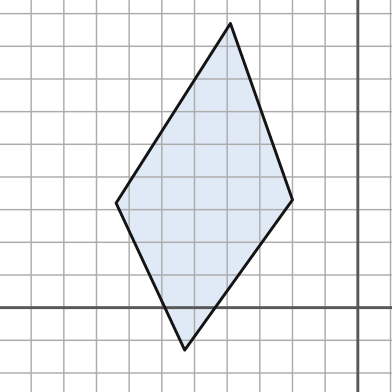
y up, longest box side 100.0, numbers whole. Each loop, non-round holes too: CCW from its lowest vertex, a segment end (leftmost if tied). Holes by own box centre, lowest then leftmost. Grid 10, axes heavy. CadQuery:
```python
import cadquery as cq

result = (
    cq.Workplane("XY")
    .moveTo(-53.0, -13.0)
    .lineTo(-20.0, 33.0)
    .lineTo(-39.0, 87.0)
    .lineTo(-74.0, 32.0)
    .close()
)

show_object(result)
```